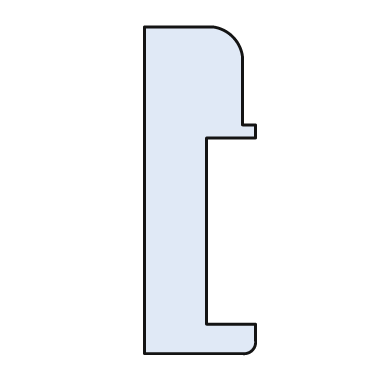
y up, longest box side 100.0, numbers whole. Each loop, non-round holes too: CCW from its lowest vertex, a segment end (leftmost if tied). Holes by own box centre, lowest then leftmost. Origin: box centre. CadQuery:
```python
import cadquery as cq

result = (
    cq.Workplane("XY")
    .moveTo(-17.0, -50.0)
    .lineTo(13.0, -50.0)
    .threePointArc((16.0, -49.0), (17.0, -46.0))
    .lineTo(17.0, -41.0)
    .lineTo(2.0, -41.0)
    .lineTo(2.0, 16.0)
    .lineTo(17.0, 16.0)
    .lineTo(17.0, 20.0)
    .lineTo(13.0, 20.0)
    .lineTo(13.0, 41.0)
    .threePointArc((10.0, 47.0), (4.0, 50.0))
    .lineTo(-17.0, 50.0)
    .close()
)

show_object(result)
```